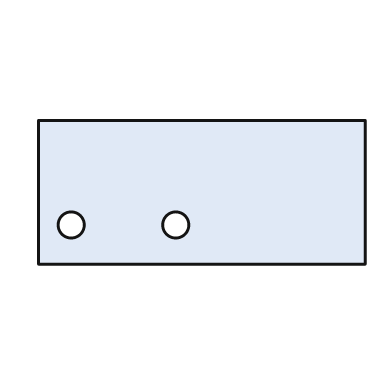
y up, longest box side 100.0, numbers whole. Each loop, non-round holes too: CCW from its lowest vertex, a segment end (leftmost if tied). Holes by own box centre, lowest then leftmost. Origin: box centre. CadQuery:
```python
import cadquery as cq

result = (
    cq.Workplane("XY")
    .moveTo(-50.0, -22.0)
    .lineTo(50.0, -22.0)
    .lineTo(50.0, 22.0)
    .lineTo(-50.0, 22.0)
    .close()
    .moveTo(-40.0, -10.0)
    .circle(4.0)
    .moveTo(-8.0, -10.0)
    .circle(4.0)
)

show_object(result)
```